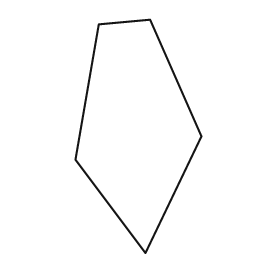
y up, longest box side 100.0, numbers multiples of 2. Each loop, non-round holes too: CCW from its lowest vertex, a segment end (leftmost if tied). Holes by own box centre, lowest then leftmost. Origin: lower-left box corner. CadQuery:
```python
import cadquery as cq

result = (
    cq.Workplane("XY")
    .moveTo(30.0, 0.0)
    .lineTo(54.0, 50.0)
    .lineTo(32.0, 100.0)
    .lineTo(10.0, 98.0)
    .lineTo(0.0, 40.0)
    .close()
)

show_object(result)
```